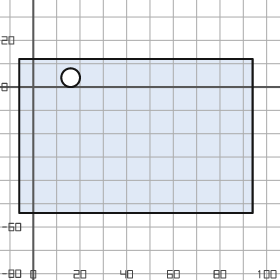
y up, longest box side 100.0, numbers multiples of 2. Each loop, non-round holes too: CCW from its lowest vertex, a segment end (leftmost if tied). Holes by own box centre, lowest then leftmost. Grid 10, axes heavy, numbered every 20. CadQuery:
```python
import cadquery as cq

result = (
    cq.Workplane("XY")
    .moveTo(-6.0, -54.0)
    .lineTo(94.0, -54.0)
    .lineTo(94.0, 12.0)
    .lineTo(-6.0, 12.0)
    .close()
    .moveTo(16.0, 4.0)
    .circle(4.0)
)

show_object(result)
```